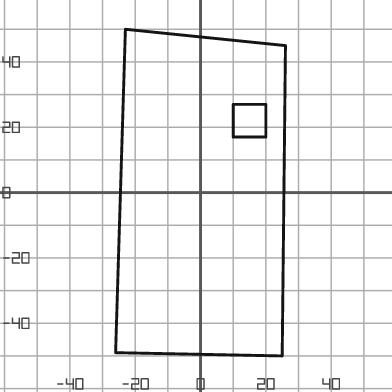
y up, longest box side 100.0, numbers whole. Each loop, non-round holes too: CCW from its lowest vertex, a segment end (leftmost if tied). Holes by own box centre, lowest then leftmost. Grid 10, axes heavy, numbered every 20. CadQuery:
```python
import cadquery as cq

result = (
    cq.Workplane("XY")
    .moveTo(25.0, -50.0)
    .lineTo(26.0, 45.0)
    .lineTo(-23.0, 50.0)
    .lineTo(-26.0, -49.0)
    .close()
    .moveTo(10.0, 17.0)
    .lineTo(20.0, 17.0)
    .lineTo(20.0, 27.0)
    .lineTo(10.0, 27.0)
    .close()
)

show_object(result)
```